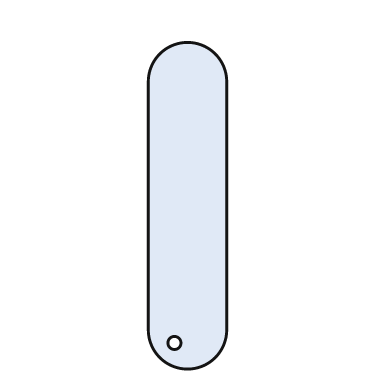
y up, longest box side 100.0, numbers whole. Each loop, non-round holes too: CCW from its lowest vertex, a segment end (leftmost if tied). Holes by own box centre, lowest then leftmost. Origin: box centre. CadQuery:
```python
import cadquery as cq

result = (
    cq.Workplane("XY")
    .moveTo(-12.0, -38.0)
    .threePointArc((0.0, -50.0), (12.0, -38.0))
    .lineTo(12.0, 38.0)
    .threePointArc((0.0, 50.0), (-12.0, 38.0))
    .close()
    .moveTo(-4.0, -42.0)
    .circle(2.0)
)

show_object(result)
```